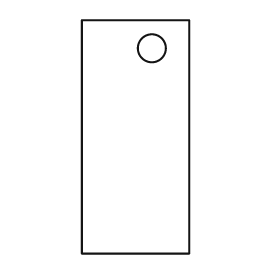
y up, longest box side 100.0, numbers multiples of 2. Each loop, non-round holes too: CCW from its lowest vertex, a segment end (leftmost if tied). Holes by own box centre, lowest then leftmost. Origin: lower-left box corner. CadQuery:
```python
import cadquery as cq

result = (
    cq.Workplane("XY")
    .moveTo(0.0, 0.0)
    .lineTo(46.0, 0.0)
    .lineTo(46.0, 100.0)
    .lineTo(0.0, 100.0)
    .close()
    .moveTo(30.0, 88.0)
    .circle(6.0)
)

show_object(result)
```